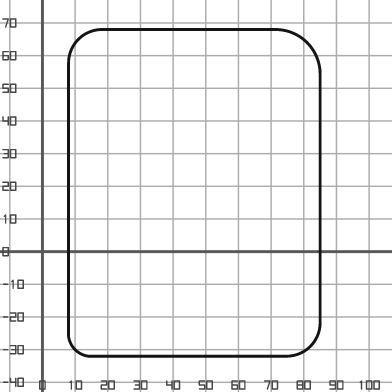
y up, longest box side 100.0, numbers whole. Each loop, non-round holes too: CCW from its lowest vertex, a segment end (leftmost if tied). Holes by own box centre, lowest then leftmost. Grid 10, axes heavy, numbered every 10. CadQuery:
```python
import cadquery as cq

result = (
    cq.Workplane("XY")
    .moveTo(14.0, -32.0)
    .lineTo(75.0, -32.0)
    .threePointArc((82.0, -29.0), (85.0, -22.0))
    .lineTo(85.0, 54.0)
    .threePointArc((81.0, 64.0), (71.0, 68.0))
    .lineTo(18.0, 68.0)
    .threePointArc((11.0, 65.0), (8.0, 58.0))
    .lineTo(8.0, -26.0)
    .threePointArc((10.0, -30.0), (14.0, -32.0))
    .close()
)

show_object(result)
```